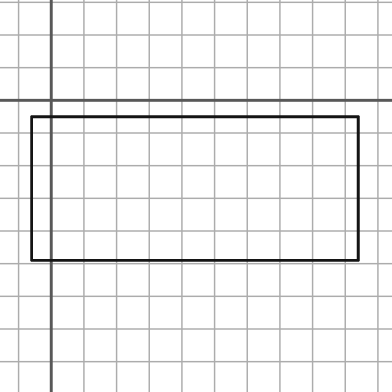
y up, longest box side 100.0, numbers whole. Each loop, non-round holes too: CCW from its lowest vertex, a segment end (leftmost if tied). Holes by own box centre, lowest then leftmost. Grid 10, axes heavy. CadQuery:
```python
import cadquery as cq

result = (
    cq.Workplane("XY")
    .moveTo(-6.0, -49.0)
    .lineTo(94.0, -49.0)
    .lineTo(94.0, -5.0)
    .lineTo(-6.0, -5.0)
    .close()
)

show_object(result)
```